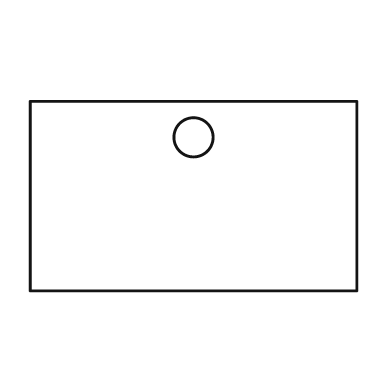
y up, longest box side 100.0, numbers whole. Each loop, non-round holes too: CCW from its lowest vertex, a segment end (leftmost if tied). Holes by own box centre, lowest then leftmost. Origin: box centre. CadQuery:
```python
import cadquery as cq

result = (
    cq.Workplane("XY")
    .moveTo(-50.0, -29.0)
    .lineTo(50.0, -29.0)
    .lineTo(50.0, 29.0)
    .lineTo(-50.0, 29.0)
    .close()
    .moveTo(0.0, 18.0)
    .circle(6.0)
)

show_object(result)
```